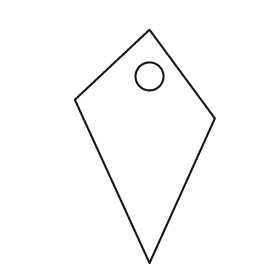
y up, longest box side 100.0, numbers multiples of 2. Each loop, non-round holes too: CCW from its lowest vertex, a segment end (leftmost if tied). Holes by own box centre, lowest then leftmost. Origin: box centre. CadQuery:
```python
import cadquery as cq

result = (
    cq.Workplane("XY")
    .moveTo(2.0, -50.0)
    .lineTo(30.0, 12.0)
    .lineTo(2.0, 50.0)
    .lineTo(-30.0, 20.0)
    .close()
    .moveTo(2.0, 30.0)
    .circle(6.0)
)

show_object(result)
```